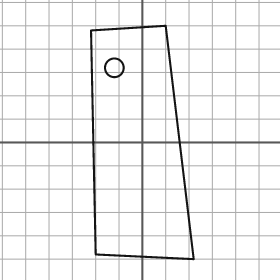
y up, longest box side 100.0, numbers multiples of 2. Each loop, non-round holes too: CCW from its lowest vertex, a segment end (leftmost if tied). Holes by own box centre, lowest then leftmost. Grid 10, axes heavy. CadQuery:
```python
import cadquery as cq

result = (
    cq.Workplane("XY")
    .moveTo(22.0, -50.0)
    .lineTo(10.0, 50.0)
    .lineTo(-22.0, 48.0)
    .lineTo(-20.0, -48.0)
    .close()
    .moveTo(-12.0, 32.0)
    .circle(4.0)
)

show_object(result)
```